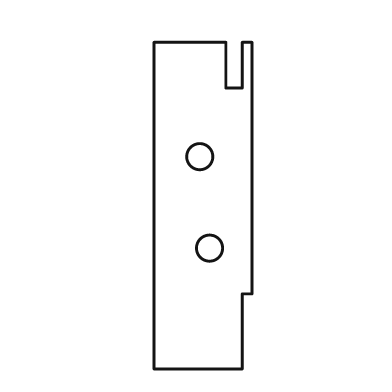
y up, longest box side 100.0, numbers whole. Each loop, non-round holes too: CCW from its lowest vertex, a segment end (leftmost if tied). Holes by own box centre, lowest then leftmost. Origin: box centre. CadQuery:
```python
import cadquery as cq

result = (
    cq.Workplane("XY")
    .moveTo(-15.0, -50.0)
    .lineTo(12.0, -50.0)
    .lineTo(12.0, -27.0)
    .lineTo(15.0, -27.0)
    .lineTo(15.0, 50.0)
    .lineTo(12.0, 50.0)
    .lineTo(12.0, 36.0)
    .lineTo(7.0, 36.0)
    .lineTo(7.0, 50.0)
    .lineTo(-15.0, 50.0)
    .close()
    .moveTo(2.0, -13.0)
    .circle(4.0)
    .moveTo(-1.0, 15.0)
    .circle(4.0)
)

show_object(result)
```